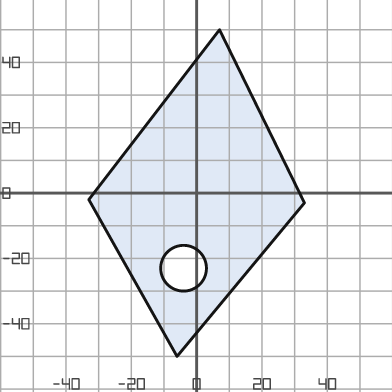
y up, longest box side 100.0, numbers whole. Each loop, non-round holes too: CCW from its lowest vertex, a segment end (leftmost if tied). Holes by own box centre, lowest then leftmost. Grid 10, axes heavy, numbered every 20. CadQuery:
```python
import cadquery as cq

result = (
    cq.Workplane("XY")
    .moveTo(-6.0, -50.0)
    .lineTo(33.0, -3.0)
    .lineTo(7.0, 50.0)
    .lineTo(-33.0, -2.0)
    .close()
    .moveTo(-4.0, -23.0)
    .circle(7.0)
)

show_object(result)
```